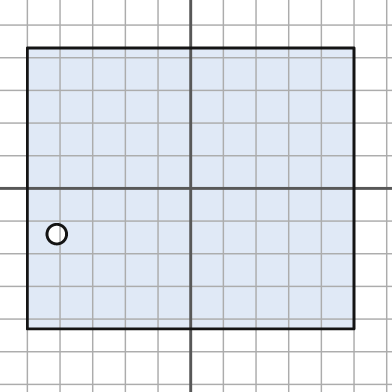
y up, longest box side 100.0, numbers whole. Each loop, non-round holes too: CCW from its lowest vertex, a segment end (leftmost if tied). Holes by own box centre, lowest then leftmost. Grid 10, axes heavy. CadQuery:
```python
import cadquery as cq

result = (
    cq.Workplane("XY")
    .moveTo(-50.0, -43.0)
    .lineTo(50.0, -43.0)
    .lineTo(50.0, 43.0)
    .lineTo(-50.0, 43.0)
    .close()
    .moveTo(-41.0, -14.0)
    .circle(3.0)
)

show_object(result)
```